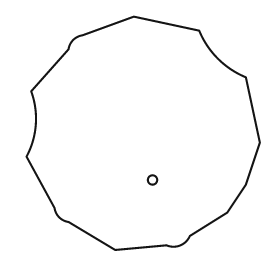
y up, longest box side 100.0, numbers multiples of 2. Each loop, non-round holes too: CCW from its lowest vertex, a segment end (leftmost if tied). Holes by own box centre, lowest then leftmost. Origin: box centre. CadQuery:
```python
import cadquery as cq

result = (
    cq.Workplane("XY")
    .moveTo(-12.0, -50.0)
    .lineTo(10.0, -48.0)
    .threePointArc((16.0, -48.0), (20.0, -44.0))
    .lineTo(36.0, -34.0)
    .lineTo(44.0, -22.0)
    .lineTo(50.0, -4.0)
    .lineTo(44.0, 24.0)
    .threePointArc((32.0, 32.0), (24.0, 44.0))
    .lineTo(-4.0, 50.0)
    .lineTo(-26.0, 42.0)
    .threePointArc((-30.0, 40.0), (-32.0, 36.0))
    .lineTo(-48.0, 18.0)
    .threePointArc((-46.0, 4.0), (-50.0, -10.0))
    .lineTo(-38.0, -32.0)
    .threePointArc((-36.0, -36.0), (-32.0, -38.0))
    .close()
    .moveTo(4.0, -20.0)
    .circle(2.0)
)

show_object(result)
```